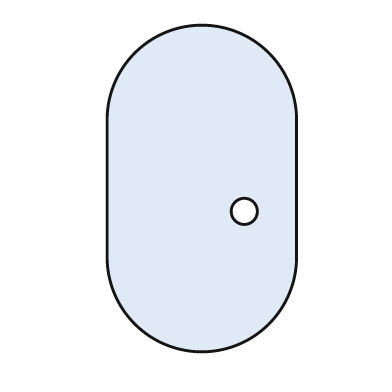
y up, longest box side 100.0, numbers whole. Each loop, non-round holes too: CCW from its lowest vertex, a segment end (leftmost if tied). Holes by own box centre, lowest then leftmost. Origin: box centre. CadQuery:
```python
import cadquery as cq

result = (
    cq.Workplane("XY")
    .moveTo(-29.0, -21.0)
    .threePointArc((0.0, -50.0), (29.0, -21.0))
    .lineTo(29.0, 21.0)
    .threePointArc((0.0, 50.0), (-29.0, 21.0))
    .close()
    .moveTo(13.0, -7.0)
    .circle(4.0)
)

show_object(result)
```